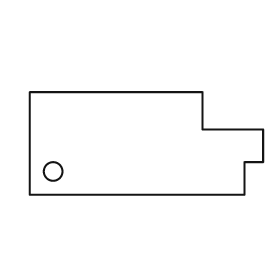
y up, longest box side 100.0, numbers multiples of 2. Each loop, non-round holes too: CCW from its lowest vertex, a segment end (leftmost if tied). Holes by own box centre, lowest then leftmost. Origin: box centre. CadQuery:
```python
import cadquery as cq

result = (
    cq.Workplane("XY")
    .moveTo(-50.0, -22.0)
    .lineTo(42.0, -22.0)
    .lineTo(42.0, -8.0)
    .lineTo(50.0, -8.0)
    .lineTo(50.0, 6.0)
    .lineTo(24.0, 6.0)
    .lineTo(24.0, 22.0)
    .lineTo(-50.0, 22.0)
    .close()
    .moveTo(-40.0, -12.0)
    .circle(4.0)
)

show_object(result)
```